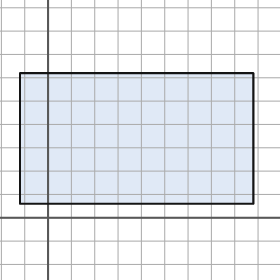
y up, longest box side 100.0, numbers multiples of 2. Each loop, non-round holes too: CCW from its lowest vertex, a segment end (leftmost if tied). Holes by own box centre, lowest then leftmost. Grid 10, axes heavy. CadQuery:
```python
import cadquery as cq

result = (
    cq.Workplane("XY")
    .moveTo(-12.0, 6.0)
    .lineTo(88.0, 6.0)
    .lineTo(88.0, 62.0)
    .lineTo(-12.0, 62.0)
    .close()
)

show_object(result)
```